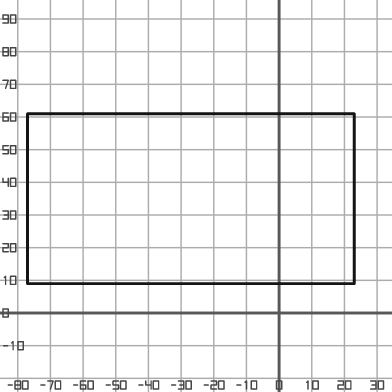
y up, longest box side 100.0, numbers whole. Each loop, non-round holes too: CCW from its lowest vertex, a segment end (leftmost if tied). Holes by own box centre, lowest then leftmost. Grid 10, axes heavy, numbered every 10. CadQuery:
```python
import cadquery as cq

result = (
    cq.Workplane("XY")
    .moveTo(-77.0, 9.0)
    .lineTo(23.0, 9.0)
    .lineTo(23.0, 61.0)
    .lineTo(-77.0, 61.0)
    .close()
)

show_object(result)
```